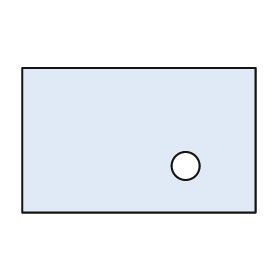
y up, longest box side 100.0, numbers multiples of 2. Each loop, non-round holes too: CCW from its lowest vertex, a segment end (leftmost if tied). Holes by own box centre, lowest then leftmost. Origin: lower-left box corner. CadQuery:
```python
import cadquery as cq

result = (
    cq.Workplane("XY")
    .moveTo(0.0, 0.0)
    .lineTo(100.0, 0.0)
    .lineTo(100.0, 62.0)
    .lineTo(0.0, 62.0)
    .close()
    .moveTo(70.0, 20.0)
    .circle(6.0)
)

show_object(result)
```